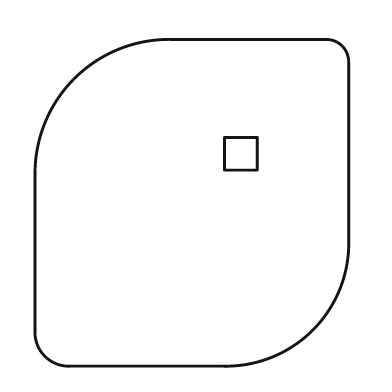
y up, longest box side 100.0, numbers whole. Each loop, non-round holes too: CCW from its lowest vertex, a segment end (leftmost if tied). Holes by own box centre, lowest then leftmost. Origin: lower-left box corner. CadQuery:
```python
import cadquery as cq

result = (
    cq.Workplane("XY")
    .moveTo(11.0, 0.0)
    .lineTo(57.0, 0.0)
    .threePointArc((85.0, 11.0), (96.0, 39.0))
    .lineTo(96.0, 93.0)
    .threePointArc((94.0, 98.0), (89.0, 100.0))
    .lineTo(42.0, 100.0)
    .threePointArc((12.0, 88.0), (0.0, 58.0))
    .lineTo(0.0, 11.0)
    .threePointArc((3.0, 3.0), (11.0, 0.0))
    .close()
    .moveTo(58.0, 60.0)
    .lineTo(68.0, 60.0)
    .lineTo(68.0, 70.0)
    .lineTo(58.0, 70.0)
    .close()
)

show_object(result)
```